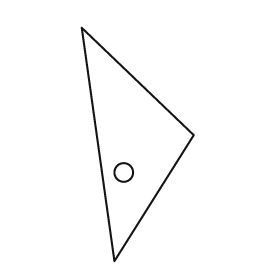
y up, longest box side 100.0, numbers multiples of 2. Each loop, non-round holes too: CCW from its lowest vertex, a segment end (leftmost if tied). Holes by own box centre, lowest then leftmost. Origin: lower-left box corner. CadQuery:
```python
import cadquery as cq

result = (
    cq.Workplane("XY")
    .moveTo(14.0, 0.0)
    .lineTo(48.0, 54.0)
    .lineTo(0.0, 100.0)
    .close()
    .moveTo(18.0, 38.0)
    .circle(4.0)
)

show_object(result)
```